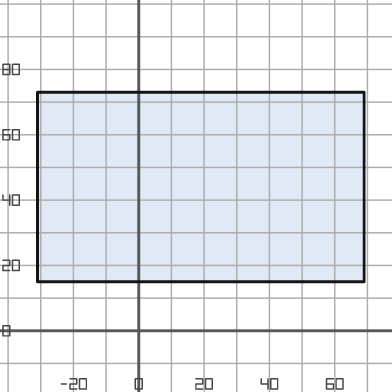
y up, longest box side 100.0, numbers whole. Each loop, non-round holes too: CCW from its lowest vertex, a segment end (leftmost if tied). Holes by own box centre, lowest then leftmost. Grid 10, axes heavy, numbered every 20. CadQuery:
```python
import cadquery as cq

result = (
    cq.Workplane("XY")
    .moveTo(-31.0, 15.0)
    .lineTo(69.0, 15.0)
    .lineTo(69.0, 73.0)
    .lineTo(-31.0, 73.0)
    .close()
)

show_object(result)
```